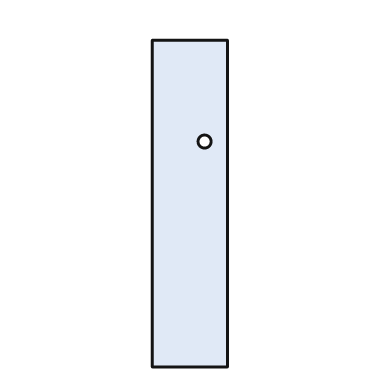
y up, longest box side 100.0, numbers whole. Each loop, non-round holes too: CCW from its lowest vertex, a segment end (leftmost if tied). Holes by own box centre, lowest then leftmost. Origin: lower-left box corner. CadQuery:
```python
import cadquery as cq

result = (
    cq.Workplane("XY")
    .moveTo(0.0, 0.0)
    .lineTo(23.0, 0.0)
    .lineTo(23.0, 100.0)
    .lineTo(0.0, 100.0)
    .close()
    .moveTo(16.0, 69.0)
    .circle(2.0)
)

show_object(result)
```